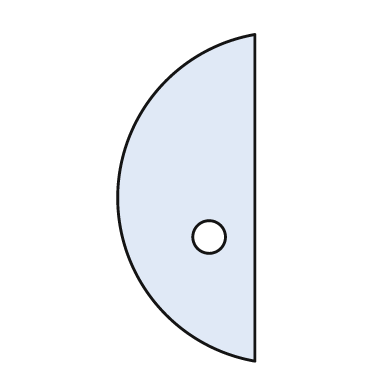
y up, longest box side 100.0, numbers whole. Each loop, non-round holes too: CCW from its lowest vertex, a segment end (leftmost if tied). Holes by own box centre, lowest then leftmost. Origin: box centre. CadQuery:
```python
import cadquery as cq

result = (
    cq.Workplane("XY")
    .moveTo(21.0, -50.0)
    .lineTo(21.0, 50.0)
    .threePointArc((-21.0, 0.0), (21.0, -50.0))
    .close()
    .moveTo(7.0, -12.0)
    .circle(5.0)
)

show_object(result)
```